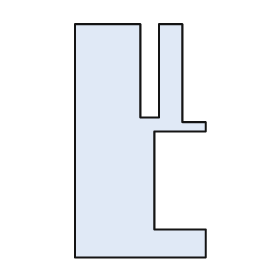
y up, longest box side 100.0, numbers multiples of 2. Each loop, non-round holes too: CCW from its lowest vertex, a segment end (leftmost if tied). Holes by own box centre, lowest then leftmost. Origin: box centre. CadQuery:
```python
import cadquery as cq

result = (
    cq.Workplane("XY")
    .moveTo(-28.0, -50.0)
    .lineTo(28.0, -50.0)
    .lineTo(28.0, -38.0)
    .lineTo(6.0, -38.0)
    .lineTo(6.0, 4.0)
    .lineTo(28.0, 4.0)
    .lineTo(28.0, 8.0)
    .lineTo(18.0, 8.0)
    .lineTo(18.0, 50.0)
    .lineTo(8.0, 50.0)
    .lineTo(8.0, 10.0)
    .lineTo(0.0, 10.0)
    .lineTo(0.0, 50.0)
    .lineTo(-28.0, 50.0)
    .close()
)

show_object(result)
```